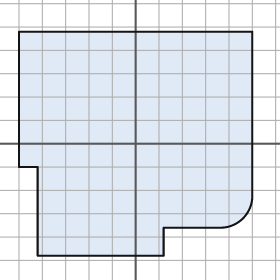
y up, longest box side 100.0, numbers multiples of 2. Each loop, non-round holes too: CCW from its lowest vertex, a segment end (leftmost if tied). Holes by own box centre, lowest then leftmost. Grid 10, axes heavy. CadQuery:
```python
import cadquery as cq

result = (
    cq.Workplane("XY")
    .moveTo(-42.0, -48.0)
    .lineTo(12.0, -48.0)
    .lineTo(12.0, -36.0)
    .lineTo(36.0, -36.0)
    .threePointArc((46.0, -32.0), (50.0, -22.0))
    .lineTo(50.0, 48.0)
    .lineTo(-50.0, 48.0)
    .lineTo(-50.0, -10.0)
    .lineTo(-42.0, -10.0)
    .close()
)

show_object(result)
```